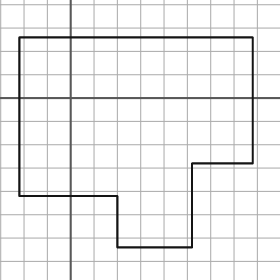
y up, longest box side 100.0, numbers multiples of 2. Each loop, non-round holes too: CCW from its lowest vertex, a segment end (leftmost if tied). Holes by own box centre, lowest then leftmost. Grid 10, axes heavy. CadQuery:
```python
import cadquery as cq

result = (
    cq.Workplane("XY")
    .moveTo(20.0, -64.0)
    .lineTo(52.0, -64.0)
    .lineTo(52.0, -28.0)
    .lineTo(78.0, -28.0)
    .lineTo(78.0, 26.0)
    .lineTo(-22.0, 26.0)
    .lineTo(-22.0, -42.0)
    .lineTo(20.0, -42.0)
    .close()
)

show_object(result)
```